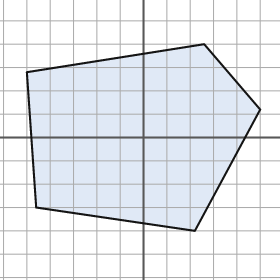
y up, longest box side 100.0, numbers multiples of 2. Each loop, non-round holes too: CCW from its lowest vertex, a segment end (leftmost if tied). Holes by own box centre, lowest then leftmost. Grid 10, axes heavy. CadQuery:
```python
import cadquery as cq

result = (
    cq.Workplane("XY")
    .moveTo(22.0, -40.0)
    .lineTo(50.0, 12.0)
    .lineTo(26.0, 40.0)
    .lineTo(-50.0, 28.0)
    .lineTo(-46.0, -30.0)
    .close()
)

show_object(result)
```